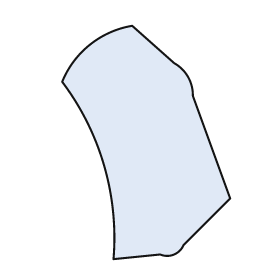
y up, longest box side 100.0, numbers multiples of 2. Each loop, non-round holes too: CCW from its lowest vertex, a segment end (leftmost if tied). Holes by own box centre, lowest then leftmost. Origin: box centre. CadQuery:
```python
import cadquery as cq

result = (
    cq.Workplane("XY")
    .moveTo(-14.0, -50.0)
    .lineTo(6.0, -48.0)
    .threePointArc((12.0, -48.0), (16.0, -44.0))
    .lineTo(36.0, -24.0)
    .lineTo(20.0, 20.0)
    .threePointArc((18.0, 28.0), (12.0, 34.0))
    .lineTo(-6.0, 50.0)
    .threePointArc((-24.0, 42.0), (-36.0, 26.0))
    .threePointArc((-18.0, -10.0), (-14.0, -50.0))
    .close()
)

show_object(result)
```